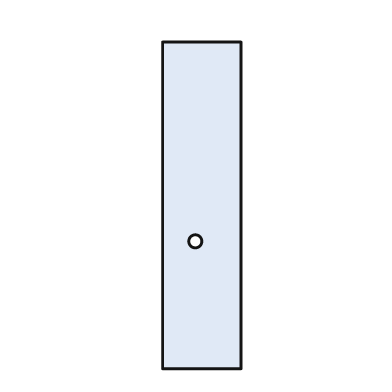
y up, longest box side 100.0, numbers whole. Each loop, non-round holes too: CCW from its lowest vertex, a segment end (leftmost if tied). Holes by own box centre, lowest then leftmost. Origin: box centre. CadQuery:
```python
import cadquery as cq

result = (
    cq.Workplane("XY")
    .moveTo(-12.0, -50.0)
    .lineTo(12.0, -50.0)
    .lineTo(12.0, 50.0)
    .lineTo(-12.0, 50.0)
    .close()
    .moveTo(-2.0, -11.0)
    .circle(2.0)
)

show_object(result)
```